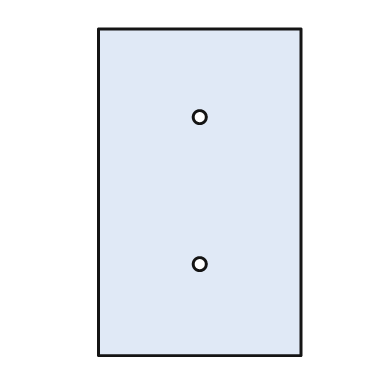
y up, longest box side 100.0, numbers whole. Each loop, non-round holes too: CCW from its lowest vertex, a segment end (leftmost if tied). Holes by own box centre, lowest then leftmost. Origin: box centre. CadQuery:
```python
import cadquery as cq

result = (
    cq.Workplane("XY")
    .moveTo(-31.0, -50.0)
    .lineTo(31.0, -50.0)
    .lineTo(31.0, 50.0)
    .lineTo(-31.0, 50.0)
    .close()
    .moveTo(0.0, -22.0)
    .circle(2.0)
    .moveTo(0.0, 23.0)
    .circle(2.0)
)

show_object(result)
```